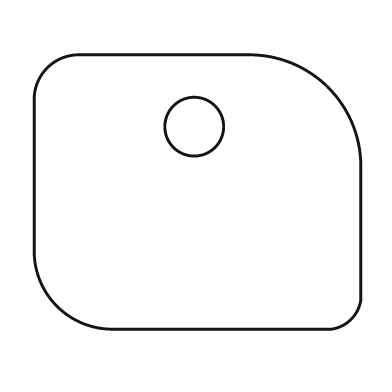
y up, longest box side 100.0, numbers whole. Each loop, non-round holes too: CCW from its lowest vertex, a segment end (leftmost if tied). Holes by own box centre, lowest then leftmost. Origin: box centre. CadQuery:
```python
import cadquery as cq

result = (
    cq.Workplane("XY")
    .moveTo(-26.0, -42.0)
    .lineTo(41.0, -42.0)
    .threePointArc((47.0, -39.0), (50.0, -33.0))
    .lineTo(50.0, 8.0)
    .threePointArc((40.0, 32.0), (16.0, 42.0))
    .lineTo(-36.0, 42.0)
    .threePointArc((-46.0, 38.0), (-50.0, 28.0))
    .lineTo(-50.0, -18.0)
    .threePointArc((-43.0, -35.0), (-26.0, -42.0))
    .close()
    .moveTo(-1.0, 20.0)
    .circle(9.0)
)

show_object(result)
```